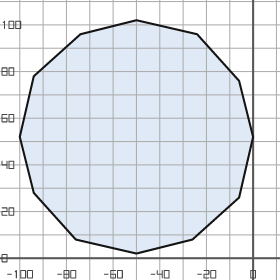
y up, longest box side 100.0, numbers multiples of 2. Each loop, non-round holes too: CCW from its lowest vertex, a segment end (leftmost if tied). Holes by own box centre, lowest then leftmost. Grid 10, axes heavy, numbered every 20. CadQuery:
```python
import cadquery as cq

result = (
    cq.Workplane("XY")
    .moveTo(-50.0, 2.0)
    .lineTo(-26.0, 8.0)
    .lineTo(-6.0, 26.0)
    .lineTo(0.0, 52.0)
    .lineTo(-6.0, 76.0)
    .lineTo(-24.0, 96.0)
    .lineTo(-50.0, 102.0)
    .lineTo(-74.0, 96.0)
    .lineTo(-94.0, 78.0)
    .lineTo(-100.0, 52.0)
    .lineTo(-94.0, 28.0)
    .lineTo(-76.0, 8.0)
    .close()
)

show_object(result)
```